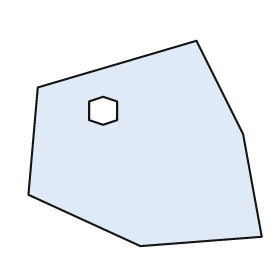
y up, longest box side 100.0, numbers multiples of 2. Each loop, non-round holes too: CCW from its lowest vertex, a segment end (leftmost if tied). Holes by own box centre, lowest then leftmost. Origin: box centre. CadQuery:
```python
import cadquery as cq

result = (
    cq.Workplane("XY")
    .moveTo(-2.0, -44.0)
    .lineTo(50.0, -40.0)
    .lineTo(42.0, 4.0)
    .lineTo(22.0, 44.0)
    .lineTo(-46.0, 24.0)
    .lineTo(-50.0, -22.0)
    .close()
    .moveTo(-18.0, 8.0)
    .lineTo(-12.0, 10.0)
    .lineTo(-12.0, 18.0)
    .lineTo(-18.0, 20.0)
    .lineTo(-24.0, 18.0)
    .lineTo(-24.0, 10.0)
    .close()
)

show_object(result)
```